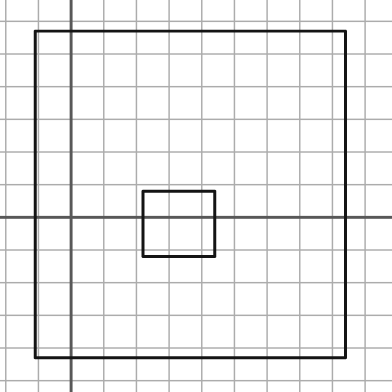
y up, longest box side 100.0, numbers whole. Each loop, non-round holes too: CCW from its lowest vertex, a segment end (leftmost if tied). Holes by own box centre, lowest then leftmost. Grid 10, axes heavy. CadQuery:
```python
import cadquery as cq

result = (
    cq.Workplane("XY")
    .moveTo(-11.0, -43.0)
    .lineTo(84.0, -43.0)
    .lineTo(84.0, 57.0)
    .lineTo(-11.0, 57.0)
    .close()
    .moveTo(22.0, -12.0)
    .lineTo(44.0, -12.0)
    .lineTo(44.0, 8.0)
    .lineTo(22.0, 8.0)
    .close()
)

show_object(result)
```